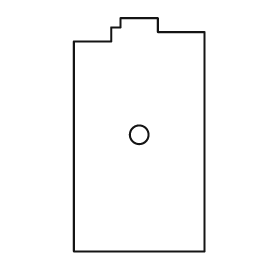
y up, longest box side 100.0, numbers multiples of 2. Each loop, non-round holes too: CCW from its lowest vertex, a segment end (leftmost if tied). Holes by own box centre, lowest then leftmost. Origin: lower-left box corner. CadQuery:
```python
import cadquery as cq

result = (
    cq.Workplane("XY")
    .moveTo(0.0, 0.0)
    .lineTo(56.0, 0.0)
    .lineTo(56.0, 94.0)
    .lineTo(36.0, 94.0)
    .lineTo(36.0, 100.0)
    .lineTo(20.0, 100.0)
    .lineTo(20.0, 96.0)
    .lineTo(16.0, 96.0)
    .lineTo(16.0, 90.0)
    .lineTo(0.0, 90.0)
    .close()
    .moveTo(28.0, 50.0)
    .circle(4.0)
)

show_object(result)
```